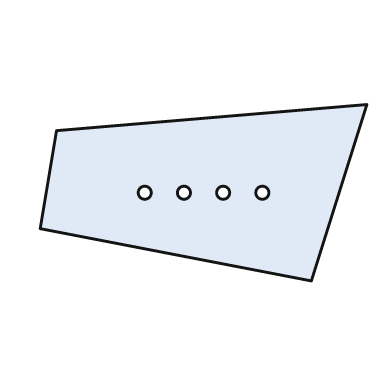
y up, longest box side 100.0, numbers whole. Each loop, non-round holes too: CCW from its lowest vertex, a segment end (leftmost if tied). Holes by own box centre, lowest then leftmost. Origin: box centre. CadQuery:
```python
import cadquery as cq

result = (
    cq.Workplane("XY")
    .moveTo(33.0, -27.0)
    .lineTo(50.0, 27.0)
    .lineTo(-45.0, 19.0)
    .lineTo(-50.0, -11.0)
    .close()
    .moveTo(-18.0, 0.0)
    .circle(2.0)
    .moveTo(-6.0, 0.0)
    .circle(2.0)
    .moveTo(6.0, 0.0)
    .circle(2.0)
    .moveTo(18.0, 0.0)
    .circle(2.0)
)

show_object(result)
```